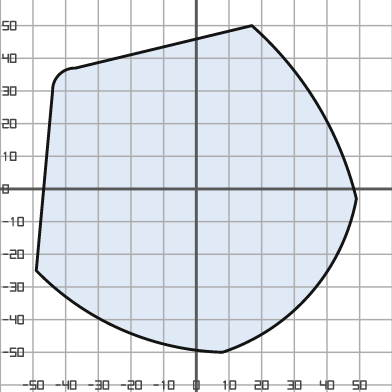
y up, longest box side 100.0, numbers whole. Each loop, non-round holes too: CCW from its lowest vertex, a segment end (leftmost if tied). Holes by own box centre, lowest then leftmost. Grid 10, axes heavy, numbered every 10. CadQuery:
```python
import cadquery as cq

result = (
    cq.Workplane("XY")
    .moveTo(8.0, -50.0)
    .threePointArc((35.0, -32.0), (49.0, -3.0))
    .threePointArc((37.0, 26.0), (17.0, 50.0))
    .lineTo(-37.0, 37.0)
    .threePointArc((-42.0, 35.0), (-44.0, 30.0))
    .lineTo(-49.0, -25.0)
    .threePointArc((-23.0, -43.0), (8.0, -50.0))
    .close()
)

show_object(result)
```